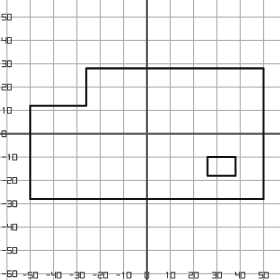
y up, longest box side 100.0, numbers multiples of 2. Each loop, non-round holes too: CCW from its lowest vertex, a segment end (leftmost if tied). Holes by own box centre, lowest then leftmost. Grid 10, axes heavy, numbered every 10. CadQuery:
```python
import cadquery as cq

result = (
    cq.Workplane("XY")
    .moveTo(-50.0, -28.0)
    .lineTo(50.0, -28.0)
    .lineTo(50.0, 28.0)
    .lineTo(-26.0, 28.0)
    .lineTo(-26.0, 12.0)
    .lineTo(-50.0, 12.0)
    .close()
    .moveTo(26.0, -18.0)
    .lineTo(38.0, -18.0)
    .lineTo(38.0, -10.0)
    .lineTo(26.0, -10.0)
    .close()
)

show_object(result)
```